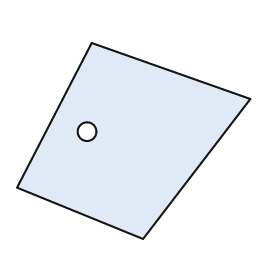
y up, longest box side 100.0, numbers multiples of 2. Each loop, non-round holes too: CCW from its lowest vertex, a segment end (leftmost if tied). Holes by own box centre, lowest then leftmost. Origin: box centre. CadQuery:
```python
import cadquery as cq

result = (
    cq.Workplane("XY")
    .moveTo(4.0, -42.0)
    .lineTo(50.0, 18.0)
    .lineTo(-18.0, 42.0)
    .lineTo(-50.0, -20.0)
    .close()
    .moveTo(-20.0, 4.0)
    .circle(4.0)
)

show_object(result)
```